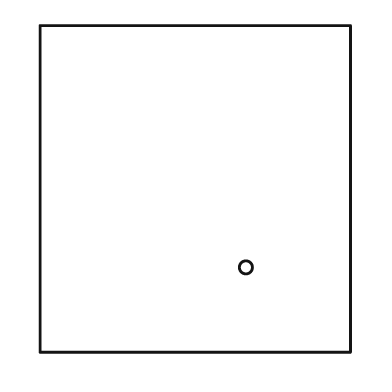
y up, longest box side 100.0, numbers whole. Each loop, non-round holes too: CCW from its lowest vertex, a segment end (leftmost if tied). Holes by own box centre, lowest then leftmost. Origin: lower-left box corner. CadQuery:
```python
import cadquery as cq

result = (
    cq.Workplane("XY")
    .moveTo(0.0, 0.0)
    .lineTo(95.0, 0.0)
    .lineTo(95.0, 100.0)
    .lineTo(0.0, 100.0)
    .close()
    .moveTo(63.0, 26.0)
    .circle(2.0)
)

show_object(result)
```